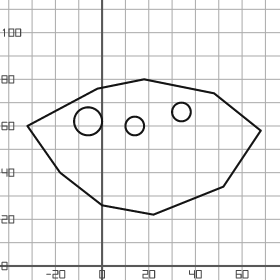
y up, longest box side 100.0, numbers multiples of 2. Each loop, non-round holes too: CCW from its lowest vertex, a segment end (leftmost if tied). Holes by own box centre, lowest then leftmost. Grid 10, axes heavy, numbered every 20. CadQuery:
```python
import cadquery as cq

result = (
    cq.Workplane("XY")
    .moveTo(22.0, 22.0)
    .lineTo(52.0, 34.0)
    .lineTo(68.0, 58.0)
    .lineTo(48.0, 74.0)
    .lineTo(18.0, 80.0)
    .lineTo(-2.0, 76.0)
    .lineTo(-32.0, 60.0)
    .lineTo(-18.0, 40.0)
    .lineTo(0.0, 26.0)
    .close()
    .moveTo(14.0, 60.0)
    .circle(4.0)
    .moveTo(-6.0, 62.0)
    .circle(6.0)
    .moveTo(34.0, 66.0)
    .circle(4.0)
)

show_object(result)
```